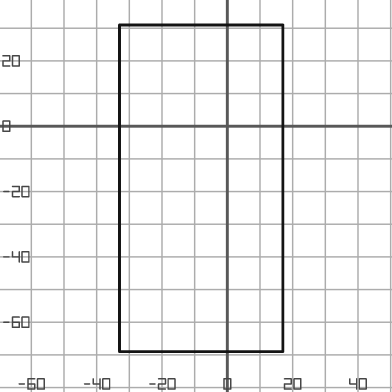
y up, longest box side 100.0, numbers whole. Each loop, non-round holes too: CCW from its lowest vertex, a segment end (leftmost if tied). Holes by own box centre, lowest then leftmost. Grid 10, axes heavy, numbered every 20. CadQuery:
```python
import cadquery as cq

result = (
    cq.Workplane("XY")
    .moveTo(-33.0, -69.0)
    .lineTo(17.0, -69.0)
    .lineTo(17.0, 31.0)
    .lineTo(-33.0, 31.0)
    .close()
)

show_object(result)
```